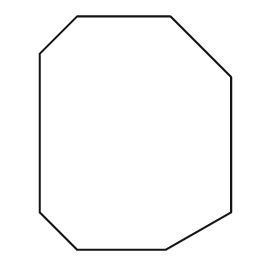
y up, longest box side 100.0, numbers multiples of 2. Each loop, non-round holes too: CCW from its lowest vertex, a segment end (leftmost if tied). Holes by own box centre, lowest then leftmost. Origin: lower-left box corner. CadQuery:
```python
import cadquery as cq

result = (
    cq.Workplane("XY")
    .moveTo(16.0, 0.0)
    .lineTo(54.0, 0.0)
    .lineTo(82.0, 16.0)
    .lineTo(82.0, 74.0)
    .lineTo(56.0, 100.0)
    .lineTo(16.0, 100.0)
    .lineTo(0.0, 84.0)
    .lineTo(0.0, 16.0)
    .close()
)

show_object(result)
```